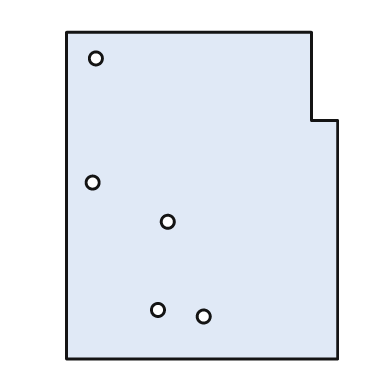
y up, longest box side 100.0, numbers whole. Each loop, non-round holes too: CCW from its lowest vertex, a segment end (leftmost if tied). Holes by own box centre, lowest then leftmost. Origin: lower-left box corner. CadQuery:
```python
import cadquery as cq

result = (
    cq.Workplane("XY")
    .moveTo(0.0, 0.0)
    .lineTo(83.0, 0.0)
    .lineTo(83.0, 73.0)
    .lineTo(75.0, 73.0)
    .lineTo(75.0, 100.0)
    .lineTo(0.0, 100.0)
    .close()
    .moveTo(42.0, 13.0)
    .circle(2.0)
    .moveTo(28.0, 15.0)
    .circle(2.0)
    .moveTo(31.0, 42.0)
    .circle(2.0)
    .moveTo(8.0, 54.0)
    .circle(2.0)
    .moveTo(9.0, 92.0)
    .circle(2.0)
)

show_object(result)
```